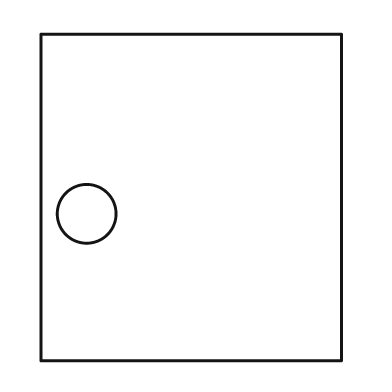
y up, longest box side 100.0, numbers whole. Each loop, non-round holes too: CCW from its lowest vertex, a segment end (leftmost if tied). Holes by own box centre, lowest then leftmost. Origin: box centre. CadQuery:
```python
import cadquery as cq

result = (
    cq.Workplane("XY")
    .moveTo(-46.0, -50.0)
    .lineTo(46.0, -50.0)
    .lineTo(46.0, 50.0)
    .lineTo(-46.0, 50.0)
    .close()
    .moveTo(-32.0, -5.0)
    .circle(9.0)
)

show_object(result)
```